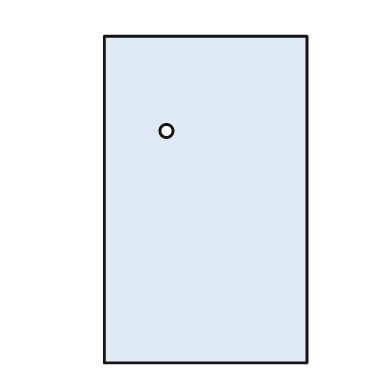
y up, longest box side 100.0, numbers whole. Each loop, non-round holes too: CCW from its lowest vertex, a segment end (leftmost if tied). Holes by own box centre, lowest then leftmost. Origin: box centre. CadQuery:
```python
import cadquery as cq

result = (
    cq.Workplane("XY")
    .moveTo(-31.0, -50.0)
    .lineTo(31.0, -50.0)
    .lineTo(31.0, 50.0)
    .lineTo(-31.0, 50.0)
    .close()
    .moveTo(-12.0, 21.0)
    .circle(2.0)
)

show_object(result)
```